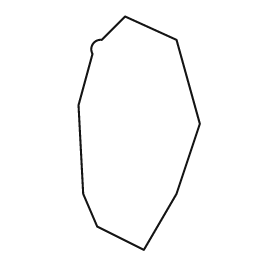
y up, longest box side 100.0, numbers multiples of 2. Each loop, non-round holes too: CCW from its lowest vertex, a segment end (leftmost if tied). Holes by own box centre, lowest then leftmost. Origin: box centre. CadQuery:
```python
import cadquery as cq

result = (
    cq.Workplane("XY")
    .moveTo(2.0, -50.0)
    .lineTo(16.0, -26.0)
    .lineTo(26.0, 4.0)
    .lineTo(16.0, 40.0)
    .lineTo(-6.0, 50.0)
    .lineTo(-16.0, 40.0)
    .threePointArc((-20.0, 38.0), (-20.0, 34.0))
    .lineTo(-26.0, 12.0)
    .lineTo(-24.0, -26.0)
    .lineTo(-18.0, -40.0)
    .close()
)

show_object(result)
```